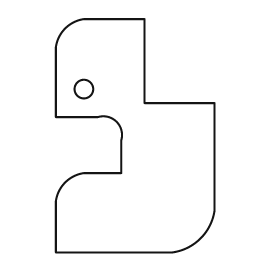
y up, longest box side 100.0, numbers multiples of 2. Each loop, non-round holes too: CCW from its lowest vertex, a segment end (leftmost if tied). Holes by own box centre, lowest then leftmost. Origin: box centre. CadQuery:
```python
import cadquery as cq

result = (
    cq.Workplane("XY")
    .moveTo(-34.0, -50.0)
    .lineTo(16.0, -50.0)
    .threePointArc((28.0, -44.0), (34.0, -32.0))
    .lineTo(34.0, 14.0)
    .lineTo(4.0, 14.0)
    .lineTo(4.0, 50.0)
    .lineTo(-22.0, 50.0)
    .threePointArc((-30.0, 46.0), (-34.0, 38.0))
    .lineTo(-34.0, 8.0)
    .lineTo(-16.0, 8.0)
    .threePointArc((-8.0, 6.0), (-6.0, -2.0))
    .lineTo(-6.0, -16.0)
    .lineTo(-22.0, -16.0)
    .threePointArc((-30.0, -20.0), (-34.0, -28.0))
    .close()
    .moveTo(-22.0, 20.0)
    .circle(4.0)
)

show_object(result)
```